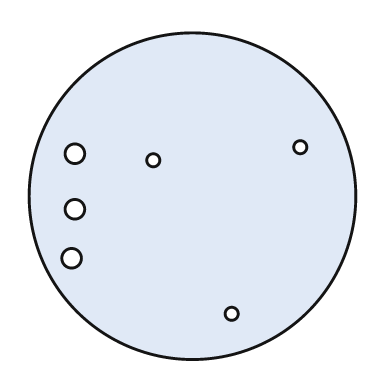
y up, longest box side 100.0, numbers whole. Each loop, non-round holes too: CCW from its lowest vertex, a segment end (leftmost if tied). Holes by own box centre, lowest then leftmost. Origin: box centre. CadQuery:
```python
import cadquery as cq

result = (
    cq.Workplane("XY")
    .moveTo(0.0, 0.0)
    .circle(50.0)
    .moveTo(12.0, -36.0)
    .circle(2.0)
    .moveTo(-37.0, -19.0)
    .circle(3.0)
    .moveTo(-36.0, -4.0)
    .circle(3.0)
    .moveTo(-12.0, 11.0)
    .circle(2.0)
    .moveTo(-36.0, 13.0)
    .circle(3.0)
    .moveTo(33.0, 15.0)
    .circle(2.0)
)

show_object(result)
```